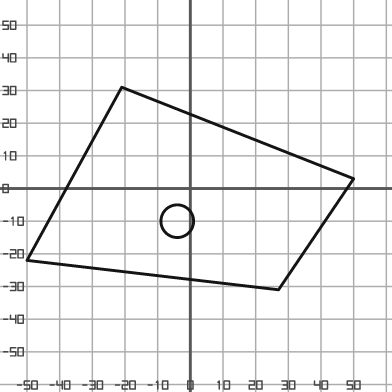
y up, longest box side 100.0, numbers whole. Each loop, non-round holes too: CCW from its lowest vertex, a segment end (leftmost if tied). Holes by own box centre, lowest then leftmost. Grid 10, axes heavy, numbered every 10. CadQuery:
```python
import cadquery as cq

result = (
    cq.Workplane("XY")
    .moveTo(27.0, -31.0)
    .lineTo(50.0, 3.0)
    .lineTo(-21.0, 31.0)
    .lineTo(-50.0, -22.0)
    .close()
    .moveTo(-4.0, -10.0)
    .circle(5.0)
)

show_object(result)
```